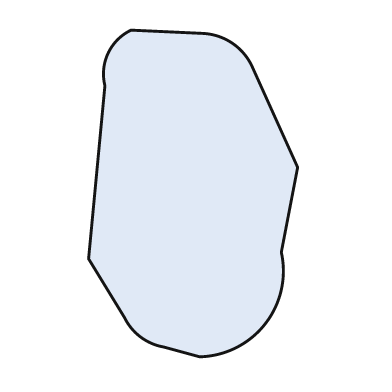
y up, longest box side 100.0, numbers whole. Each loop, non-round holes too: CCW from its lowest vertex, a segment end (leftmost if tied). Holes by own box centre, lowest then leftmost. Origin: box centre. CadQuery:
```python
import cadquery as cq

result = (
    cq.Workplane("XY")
    .moveTo(2.0, -50.0)
    .threePointArc((22.0, -40.0), (27.0, -18.0))
    .lineTo(32.0, 8.0)
    .lineTo(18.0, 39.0)
    .threePointArc((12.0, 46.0), (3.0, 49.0))
    .lineTo(-19.0, 50.0)
    .threePointArc((-26.0, 43.0), (-27.0, 33.0))
    .lineTo(-32.0, -20.0)
    .lineTo(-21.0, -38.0)
    .threePointArc((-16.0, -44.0), (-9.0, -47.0))
    .close()
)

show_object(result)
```